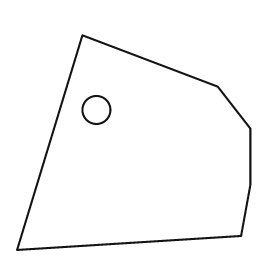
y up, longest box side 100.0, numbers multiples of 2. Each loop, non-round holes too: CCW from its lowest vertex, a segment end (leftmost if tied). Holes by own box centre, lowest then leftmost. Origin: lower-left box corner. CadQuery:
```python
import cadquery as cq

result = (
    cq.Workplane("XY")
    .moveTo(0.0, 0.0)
    .lineTo(96.0, 6.0)
    .lineTo(100.0, 28.0)
    .lineTo(100.0, 52.0)
    .lineTo(86.0, 70.0)
    .lineTo(28.0, 92.0)
    .close()
    .moveTo(34.0, 60.0)
    .circle(6.0)
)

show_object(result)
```